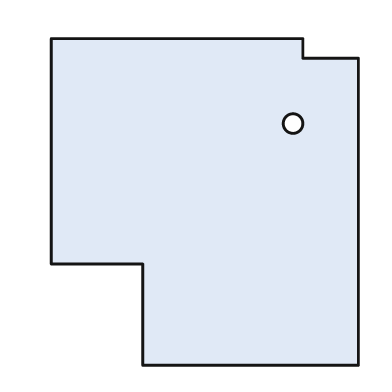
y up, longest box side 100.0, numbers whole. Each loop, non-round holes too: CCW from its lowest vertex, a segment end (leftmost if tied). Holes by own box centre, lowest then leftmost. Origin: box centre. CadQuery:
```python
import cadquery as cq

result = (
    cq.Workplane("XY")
    .moveTo(-19.0, -50.0)
    .lineTo(47.0, -50.0)
    .lineTo(47.0, 44.0)
    .lineTo(30.0, 44.0)
    .lineTo(30.0, 50.0)
    .lineTo(-47.0, 50.0)
    .lineTo(-47.0, -19.0)
    .lineTo(-19.0, -19.0)
    .close()
    .moveTo(27.0, 24.0)
    .circle(3.0)
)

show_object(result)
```